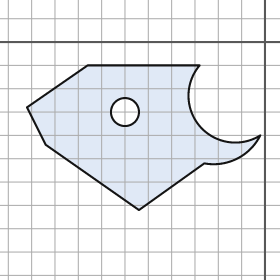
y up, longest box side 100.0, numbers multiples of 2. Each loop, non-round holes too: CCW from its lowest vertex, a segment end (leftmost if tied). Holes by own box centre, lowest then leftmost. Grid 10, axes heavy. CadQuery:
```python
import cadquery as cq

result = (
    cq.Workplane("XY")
    .moveTo(-54.0, -72.0)
    .lineTo(-26.0, -52.0)
    .threePointArc((-12.0, -50.0), (-2.0, -40.0))
    .threePointArc((-28.0, -36.0), (-28.0, -10.0))
    .lineTo(-76.0, -10.0)
    .lineTo(-102.0, -28.0)
    .lineTo(-94.0, -44.0)
    .close()
    .moveTo(-60.0, -30.0)
    .circle(6.0)
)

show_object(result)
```